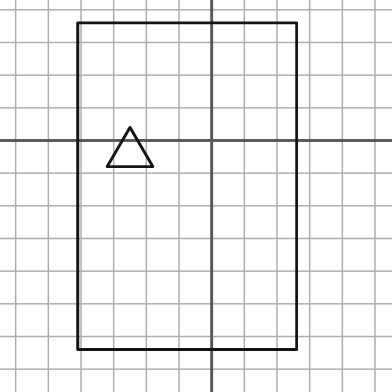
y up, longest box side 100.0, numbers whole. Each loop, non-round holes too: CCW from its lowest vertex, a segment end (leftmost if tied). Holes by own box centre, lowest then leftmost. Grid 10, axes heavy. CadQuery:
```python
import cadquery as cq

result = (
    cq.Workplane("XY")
    .moveTo(-41.0, -64.0)
    .lineTo(26.0, -64.0)
    .lineTo(26.0, 36.0)
    .lineTo(-41.0, 36.0)
    .close()
    .moveTo(-32.0, -8.0)
    .lineTo(-18.0, -8.0)
    .lineTo(-25.0, 4.0)
    .close()
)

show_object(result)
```